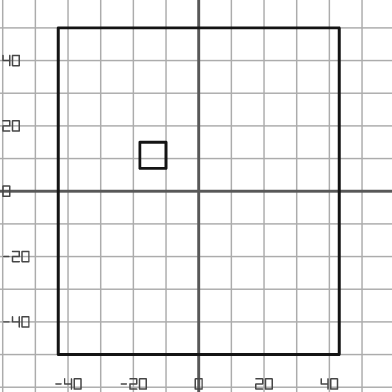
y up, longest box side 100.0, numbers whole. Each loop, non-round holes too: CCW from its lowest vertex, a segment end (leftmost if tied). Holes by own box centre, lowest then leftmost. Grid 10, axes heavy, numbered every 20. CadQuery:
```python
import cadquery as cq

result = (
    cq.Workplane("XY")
    .moveTo(-43.0, -50.0)
    .lineTo(43.0, -50.0)
    .lineTo(43.0, 50.0)
    .lineTo(-43.0, 50.0)
    .close()
    .moveTo(-18.0, 7.0)
    .lineTo(-10.0, 7.0)
    .lineTo(-10.0, 15.0)
    .lineTo(-18.0, 15.0)
    .close()
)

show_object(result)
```